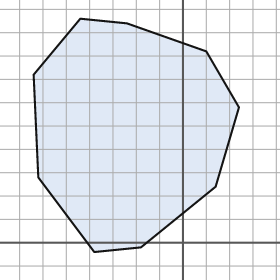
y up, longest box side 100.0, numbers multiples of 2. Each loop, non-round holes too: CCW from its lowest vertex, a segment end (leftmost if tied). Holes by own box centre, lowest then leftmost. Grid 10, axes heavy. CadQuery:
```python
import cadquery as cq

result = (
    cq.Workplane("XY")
    .moveTo(-38.0, -4.0)
    .lineTo(-18.0, -2.0)
    .lineTo(14.0, 24.0)
    .lineTo(24.0, 58.0)
    .lineTo(10.0, 82.0)
    .lineTo(-24.0, 94.0)
    .lineTo(-44.0, 96.0)
    .lineTo(-64.0, 72.0)
    .lineTo(-62.0, 28.0)
    .close()
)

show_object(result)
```